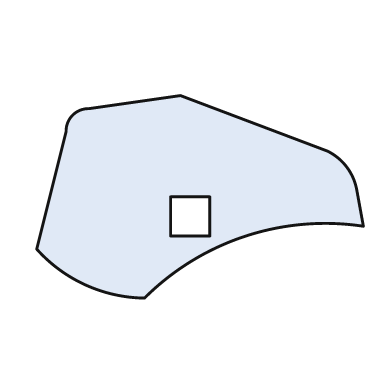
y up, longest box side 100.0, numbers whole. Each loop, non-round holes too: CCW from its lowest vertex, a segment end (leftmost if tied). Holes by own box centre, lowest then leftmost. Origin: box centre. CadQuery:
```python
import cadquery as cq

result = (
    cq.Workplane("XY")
    .moveTo(-17.0, -31.0)
    .threePointArc((14.0, -12.0), (50.0, -9.0))
    .lineTo(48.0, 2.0)
    .threePointArc((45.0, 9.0), (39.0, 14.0))
    .lineTo(-6.0, 31.0)
    .lineTo(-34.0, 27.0)
    .threePointArc((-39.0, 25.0), (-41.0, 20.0))
    .lineTo(-50.0, -16.0)
    .threePointArc((-35.0, -27.0), (-17.0, -31.0))
    .close()
    .moveTo(-9.0, -12.0)
    .lineTo(3.0, -12.0)
    .lineTo(3.0, 0.0)
    .lineTo(-9.0, 0.0)
    .close()
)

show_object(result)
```